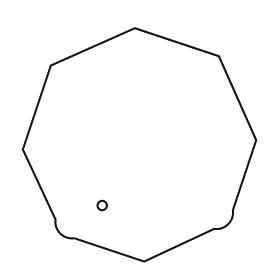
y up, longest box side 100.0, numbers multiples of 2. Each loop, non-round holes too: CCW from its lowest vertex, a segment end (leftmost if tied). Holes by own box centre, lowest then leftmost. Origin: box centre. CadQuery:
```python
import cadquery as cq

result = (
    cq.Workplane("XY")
    .moveTo(2.0, -50.0)
    .lineTo(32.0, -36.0)
    .threePointArc((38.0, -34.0), (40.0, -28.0))
    .lineTo(50.0, 2.0)
    .lineTo(34.0, 38.0)
    .lineTo(-2.0, 50.0)
    .lineTo(-38.0, 34.0)
    .lineTo(-50.0, -2.0)
    .lineTo(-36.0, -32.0)
    .threePointArc((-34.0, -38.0), (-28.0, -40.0))
    .close()
    .moveTo(-16.0, -26.0)
    .circle(2.0)
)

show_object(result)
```